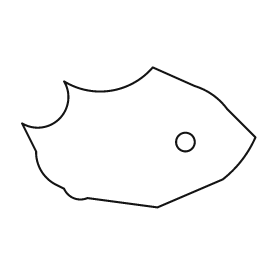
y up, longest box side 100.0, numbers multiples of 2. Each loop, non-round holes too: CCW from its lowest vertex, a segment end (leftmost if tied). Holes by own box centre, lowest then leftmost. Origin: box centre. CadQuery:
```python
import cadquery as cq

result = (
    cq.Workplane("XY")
    .moveTo(8.0, -30.0)
    .lineTo(36.0, -18.0)
    .threePointArc((44.0, -10.0), (50.0, 0.0))
    .lineTo(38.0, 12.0)
    .threePointArc((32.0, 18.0), (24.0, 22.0))
    .lineTo(6.0, 30.0)
    .threePointArc((-12.0, 20.0), (-32.0, 24.0))
    .threePointArc((-34.0, 8.0), (-50.0, 6.0))
    .lineTo(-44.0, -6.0)
    .threePointArc((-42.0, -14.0), (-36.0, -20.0))
    .lineTo(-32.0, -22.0)
    .threePointArc((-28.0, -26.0), (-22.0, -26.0))
    .close()
    .moveTo(20.0, -2.0)
    .circle(4.0)
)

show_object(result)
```